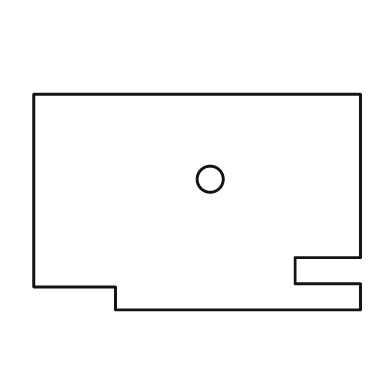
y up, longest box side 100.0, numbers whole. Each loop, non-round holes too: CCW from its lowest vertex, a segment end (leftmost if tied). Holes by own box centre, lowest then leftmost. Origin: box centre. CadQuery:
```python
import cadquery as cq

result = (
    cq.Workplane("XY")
    .moveTo(-25.0, -33.0)
    .lineTo(50.0, -33.0)
    .lineTo(50.0, -25.0)
    .lineTo(30.0, -25.0)
    .lineTo(30.0, -17.0)
    .lineTo(50.0, -17.0)
    .lineTo(50.0, 33.0)
    .lineTo(-50.0, 33.0)
    .lineTo(-50.0, -26.0)
    .lineTo(-25.0, -26.0)
    .close()
    .moveTo(4.0, 7.0)
    .circle(4.0)
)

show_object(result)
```